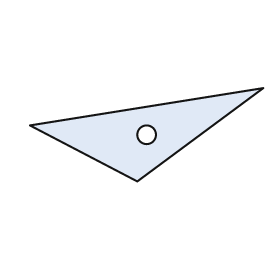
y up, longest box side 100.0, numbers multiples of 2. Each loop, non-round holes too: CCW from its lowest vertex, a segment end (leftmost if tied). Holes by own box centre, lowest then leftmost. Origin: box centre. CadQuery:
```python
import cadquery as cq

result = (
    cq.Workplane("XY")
    .moveTo(-4.0, -20.0)
    .lineTo(50.0, 20.0)
    .lineTo(-50.0, 4.0)
    .close()
    .moveTo(0.0, 0.0)
    .circle(4.0)
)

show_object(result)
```